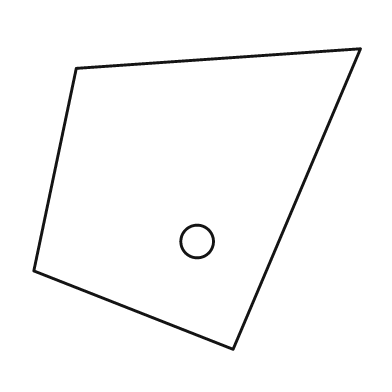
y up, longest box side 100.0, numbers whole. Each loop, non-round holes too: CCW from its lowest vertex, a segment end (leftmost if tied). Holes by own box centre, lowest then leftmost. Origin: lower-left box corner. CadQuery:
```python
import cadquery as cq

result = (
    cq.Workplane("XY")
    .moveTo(61.0, 0.0)
    .lineTo(100.0, 92.0)
    .lineTo(13.0, 86.0)
    .lineTo(0.0, 24.0)
    .close()
    .moveTo(50.0, 33.0)
    .circle(5.0)
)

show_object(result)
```